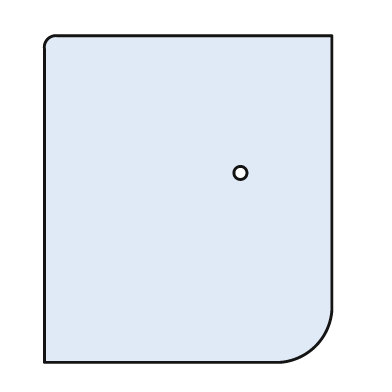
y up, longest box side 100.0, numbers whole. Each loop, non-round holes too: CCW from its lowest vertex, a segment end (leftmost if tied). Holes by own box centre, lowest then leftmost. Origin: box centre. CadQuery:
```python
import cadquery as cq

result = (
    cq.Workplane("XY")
    .moveTo(-44.0, -50.0)
    .lineTo(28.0, -50.0)
    .threePointArc((39.0, -45.0), (44.0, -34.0))
    .lineTo(44.0, 50.0)
    .lineTo(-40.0, 50.0)
    .threePointArc((-43.0, 49.0), (-44.0, 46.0))
    .close()
    .moveTo(16.0, 8.0)
    .circle(2.0)
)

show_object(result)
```